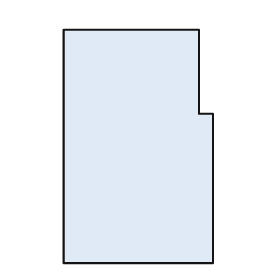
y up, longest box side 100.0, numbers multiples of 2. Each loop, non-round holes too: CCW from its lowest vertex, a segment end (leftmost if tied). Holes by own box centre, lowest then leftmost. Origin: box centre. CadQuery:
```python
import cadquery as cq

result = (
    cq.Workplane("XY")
    .moveTo(-32.0, -50.0)
    .lineTo(32.0, -50.0)
    .lineTo(32.0, 14.0)
    .lineTo(26.0, 14.0)
    .lineTo(26.0, 50.0)
    .lineTo(-32.0, 50.0)
    .close()
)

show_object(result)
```